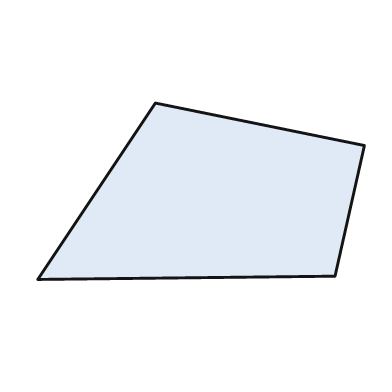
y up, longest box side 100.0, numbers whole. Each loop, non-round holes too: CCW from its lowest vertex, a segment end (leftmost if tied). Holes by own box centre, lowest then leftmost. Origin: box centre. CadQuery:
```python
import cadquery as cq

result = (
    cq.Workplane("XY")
    .moveTo(-50.0, -27.0)
    .lineTo(41.0, -26.0)
    .lineTo(50.0, 14.0)
    .lineTo(-14.0, 27.0)
    .close()
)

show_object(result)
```